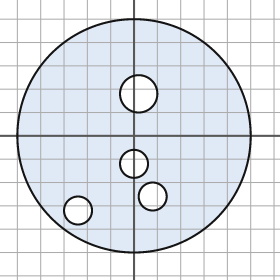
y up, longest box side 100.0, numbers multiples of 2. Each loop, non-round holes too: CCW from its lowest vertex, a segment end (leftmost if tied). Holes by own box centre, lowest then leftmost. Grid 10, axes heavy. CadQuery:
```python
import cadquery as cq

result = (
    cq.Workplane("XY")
    .moveTo(0.0, 0.0)
    .circle(50.0)
    .moveTo(-24.0, -32.0)
    .circle(6.0)
    .moveTo(8.0, -26.0)
    .circle(6.0)
    .moveTo(0.0, -12.0)
    .circle(6.0)
    .moveTo(2.0, 18.0)
    .circle(8.0)
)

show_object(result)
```